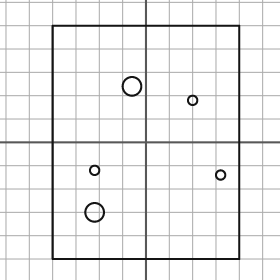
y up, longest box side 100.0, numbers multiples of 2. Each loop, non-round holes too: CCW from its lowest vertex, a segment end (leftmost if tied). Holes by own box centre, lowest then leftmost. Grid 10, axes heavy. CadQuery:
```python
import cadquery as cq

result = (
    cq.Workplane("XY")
    .moveTo(-40.0, -50.0)
    .lineTo(40.0, -50.0)
    .lineTo(40.0, 50.0)
    .lineTo(-40.0, 50.0)
    .close()
    .moveTo(-22.0, -30.0)
    .circle(4.0)
    .moveTo(32.0, -14.0)
    .circle(2.0)
    .moveTo(-22.0, -12.0)
    .circle(2.0)
    .moveTo(20.0, 18.0)
    .circle(2.0)
    .moveTo(-6.0, 24.0)
    .circle(4.0)
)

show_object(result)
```